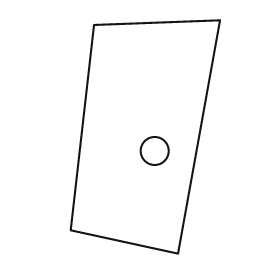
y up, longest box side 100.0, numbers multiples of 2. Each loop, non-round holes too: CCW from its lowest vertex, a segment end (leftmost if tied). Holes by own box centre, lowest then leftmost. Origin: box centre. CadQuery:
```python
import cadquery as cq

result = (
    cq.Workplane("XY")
    .moveTo(14.0, -50.0)
    .lineTo(32.0, 50.0)
    .lineTo(-22.0, 48.0)
    .lineTo(-32.0, -40.0)
    .close()
    .moveTo(4.0, -6.0)
    .circle(6.0)
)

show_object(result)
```